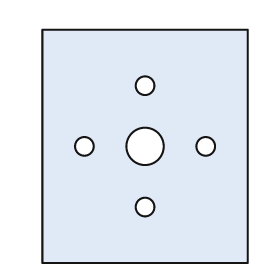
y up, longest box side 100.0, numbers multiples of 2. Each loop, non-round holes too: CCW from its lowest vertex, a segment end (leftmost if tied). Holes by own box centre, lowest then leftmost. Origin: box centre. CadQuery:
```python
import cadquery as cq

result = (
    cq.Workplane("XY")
    .moveTo(-44.0, -50.0)
    .lineTo(44.0, -50.0)
    .lineTo(44.0, 50.0)
    .lineTo(-44.0, 50.0)
    .close()
    .moveTo(0.0, -26.0)
    .circle(4.0)
    .moveTo(-26.0, 0.0)
    .circle(4.0)
    .moveTo(0.0, 0.0)
    .circle(8.0)
    .moveTo(26.0, 0.0)
    .circle(4.0)
    .moveTo(0.0, 26.0)
    .circle(4.0)
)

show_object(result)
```